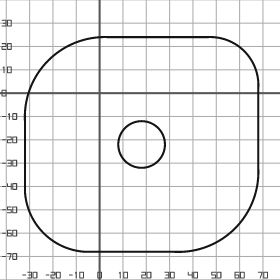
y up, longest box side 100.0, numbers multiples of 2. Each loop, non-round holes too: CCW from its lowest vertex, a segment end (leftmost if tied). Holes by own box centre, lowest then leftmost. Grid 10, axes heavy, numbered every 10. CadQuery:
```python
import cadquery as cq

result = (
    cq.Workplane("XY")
    .moveTo(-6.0, -68.0)
    .lineTo(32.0, -68.0)
    .threePointArc((58.0, -58.0), (68.0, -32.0))
    .lineTo(68.0, 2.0)
    .threePointArc((62.0, 18.0), (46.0, 24.0))
    .lineTo(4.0, 24.0)
    .threePointArc((-22.0, 14.0), (-32.0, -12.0))
    .lineTo(-32.0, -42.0)
    .threePointArc((-24.0, -60.0), (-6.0, -68.0))
    .close()
    .moveTo(18.0, -22.0)
    .circle(10.0)
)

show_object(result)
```